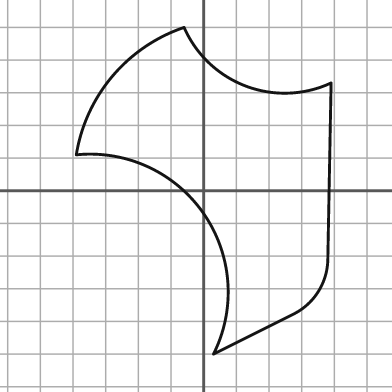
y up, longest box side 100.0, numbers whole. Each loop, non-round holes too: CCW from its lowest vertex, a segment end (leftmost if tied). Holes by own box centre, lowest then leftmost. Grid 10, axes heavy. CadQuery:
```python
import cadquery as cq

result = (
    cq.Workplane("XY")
    .moveTo(3.0, -50.0)
    .lineTo(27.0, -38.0)
    .threePointArc((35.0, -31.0), (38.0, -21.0))
    .lineTo(39.0, 33.0)
    .threePointArc((13.0, 32.0), (-6.0, 50.0))
    .threePointArc((-28.0, 35.0), (-39.0, 11.0))
    .threePointArc((0.0, -7.0), (3.0, -50.0))
    .close()
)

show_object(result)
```